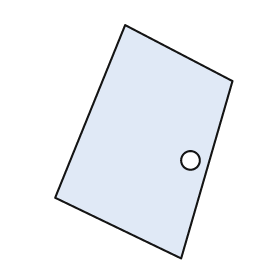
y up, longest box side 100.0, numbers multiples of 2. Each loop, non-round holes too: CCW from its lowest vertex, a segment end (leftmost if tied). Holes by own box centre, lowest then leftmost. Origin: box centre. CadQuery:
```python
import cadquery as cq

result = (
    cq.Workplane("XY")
    .moveTo(16.0, -50.0)
    .lineTo(38.0, 26.0)
    .lineTo(-8.0, 50.0)
    .lineTo(-38.0, -24.0)
    .close()
    .moveTo(20.0, -8.0)
    .circle(4.0)
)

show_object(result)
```